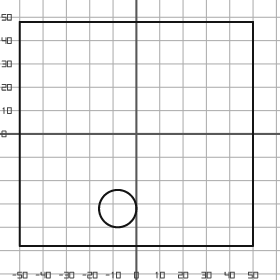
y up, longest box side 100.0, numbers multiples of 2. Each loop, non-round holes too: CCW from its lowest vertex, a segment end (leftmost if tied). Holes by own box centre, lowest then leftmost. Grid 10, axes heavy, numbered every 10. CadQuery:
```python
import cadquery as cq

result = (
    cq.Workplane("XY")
    .moveTo(-50.0, -48.0)
    .lineTo(50.0, -48.0)
    .lineTo(50.0, 48.0)
    .lineTo(-50.0, 48.0)
    .close()
    .moveTo(-8.0, -32.0)
    .circle(8.0)
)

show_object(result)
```